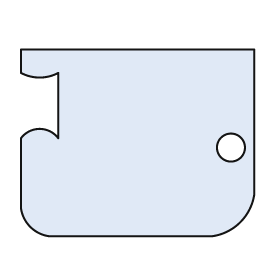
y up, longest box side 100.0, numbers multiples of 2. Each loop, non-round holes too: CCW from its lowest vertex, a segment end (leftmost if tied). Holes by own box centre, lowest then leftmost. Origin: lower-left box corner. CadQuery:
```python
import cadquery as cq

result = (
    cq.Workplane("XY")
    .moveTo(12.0, 0.0)
    .lineTo(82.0, 0.0)
    .threePointArc((94.0, 6.0), (100.0, 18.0))
    .lineTo(100.0, 80.0)
    .lineTo(0.0, 80.0)
    .lineTo(0.0, 70.0)
    .threePointArc((8.0, 68.0), (16.0, 70.0))
    .lineTo(16.0, 42.0)
    .threePointArc((8.0, 46.0), (0.0, 42.0))
    .lineTo(0.0, 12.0)
    .threePointArc((4.0, 4.0), (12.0, 0.0))
    .close()
    .moveTo(90.0, 38.0)
    .circle(6.0)
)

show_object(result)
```